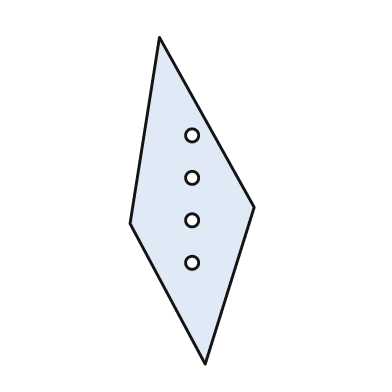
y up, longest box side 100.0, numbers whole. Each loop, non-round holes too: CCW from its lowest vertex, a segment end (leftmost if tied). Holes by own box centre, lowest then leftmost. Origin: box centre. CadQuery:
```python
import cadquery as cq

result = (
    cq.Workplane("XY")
    .moveTo(4.0, -50.0)
    .lineTo(19.0, -2.0)
    .lineTo(-10.0, 50.0)
    .lineTo(-19.0, -7.0)
    .close()
    .moveTo(0.0, -19.0)
    .circle(2.0)
    .moveTo(0.0, -6.0)
    .circle(2.0)
    .moveTo(0.0, 7.0)
    .circle(2.0)
    .moveTo(0.0, 20.0)
    .circle(2.0)
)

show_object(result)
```